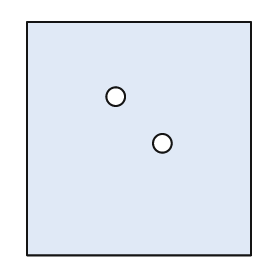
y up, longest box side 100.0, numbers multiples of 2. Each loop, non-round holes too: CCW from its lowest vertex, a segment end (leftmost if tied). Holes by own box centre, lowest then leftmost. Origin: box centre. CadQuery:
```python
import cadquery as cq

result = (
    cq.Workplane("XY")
    .moveTo(-48.0, -50.0)
    .lineTo(48.0, -50.0)
    .lineTo(48.0, 50.0)
    .lineTo(-48.0, 50.0)
    .close()
    .moveTo(10.0, -2.0)
    .circle(4.0)
    .moveTo(-10.0, 18.0)
    .circle(4.0)
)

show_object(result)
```